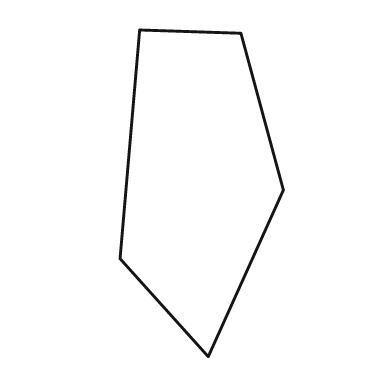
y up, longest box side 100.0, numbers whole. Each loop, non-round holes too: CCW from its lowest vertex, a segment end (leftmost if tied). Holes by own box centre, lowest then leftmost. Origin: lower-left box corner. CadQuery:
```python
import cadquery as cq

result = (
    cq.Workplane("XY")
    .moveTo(27.0, 0.0)
    .lineTo(50.0, 51.0)
    .lineTo(37.0, 99.0)
    .lineTo(6.0, 100.0)
    .lineTo(0.0, 30.0)
    .close()
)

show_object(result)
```